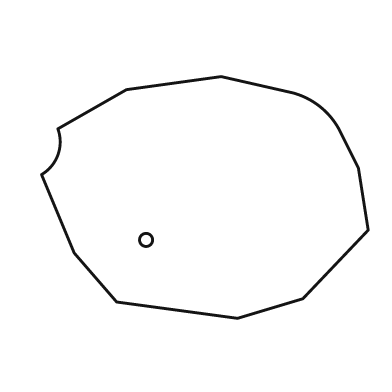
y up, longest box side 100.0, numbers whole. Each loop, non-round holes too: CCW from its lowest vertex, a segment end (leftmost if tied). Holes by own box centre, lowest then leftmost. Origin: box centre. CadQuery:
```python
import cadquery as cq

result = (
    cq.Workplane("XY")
    .moveTo(10.0, -37.0)
    .lineTo(30.0, -31.0)
    .lineTo(50.0, -10.0)
    .lineTo(47.0, 9.0)
    .lineTo(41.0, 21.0)
    .threePointArc((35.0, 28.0), (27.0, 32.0))
    .lineTo(5.0, 37.0)
    .lineTo(-24.0, 33.0)
    .lineTo(-45.0, 21.0)
    .threePointArc((-45.0, 13.0), (-50.0, 7.0))
    .lineTo(-40.0, -17.0)
    .lineTo(-27.0, -32.0)
    .close()
    .moveTo(-18.0, -13.0)
    .circle(2.0)
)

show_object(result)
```